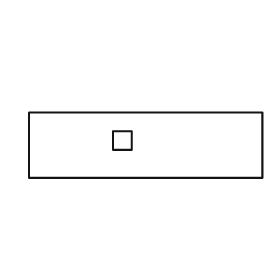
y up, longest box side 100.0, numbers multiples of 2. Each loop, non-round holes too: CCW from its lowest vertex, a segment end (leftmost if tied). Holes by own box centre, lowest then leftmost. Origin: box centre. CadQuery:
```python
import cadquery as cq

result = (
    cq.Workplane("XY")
    .moveTo(-50.0, -14.0)
    .lineTo(50.0, -14.0)
    .lineTo(50.0, 14.0)
    .lineTo(-50.0, 14.0)
    .close()
    .moveTo(-14.0, -2.0)
    .lineTo(-6.0, -2.0)
    .lineTo(-6.0, 6.0)
    .lineTo(-14.0, 6.0)
    .close()
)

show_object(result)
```